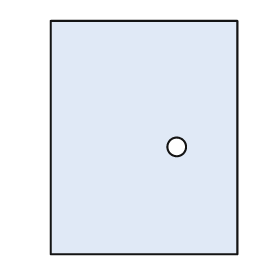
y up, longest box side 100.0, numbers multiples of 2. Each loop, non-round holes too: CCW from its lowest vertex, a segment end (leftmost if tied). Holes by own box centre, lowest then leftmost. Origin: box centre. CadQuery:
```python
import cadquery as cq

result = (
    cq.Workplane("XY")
    .moveTo(-40.0, -50.0)
    .lineTo(40.0, -50.0)
    .lineTo(40.0, 50.0)
    .lineTo(-40.0, 50.0)
    .close()
    .moveTo(14.0, -4.0)
    .circle(4.0)
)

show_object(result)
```